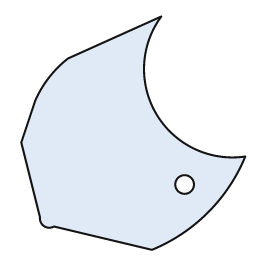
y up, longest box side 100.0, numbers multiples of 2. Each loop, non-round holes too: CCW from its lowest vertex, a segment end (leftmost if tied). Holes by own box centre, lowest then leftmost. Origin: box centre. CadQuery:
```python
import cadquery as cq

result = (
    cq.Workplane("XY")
    .moveTo(8.0, -50.0)
    .threePointArc((32.0, -34.0), (48.0, -10.0))
    .threePointArc((10.0, 8.0), (12.0, 50.0))
    .lineTo(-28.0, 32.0)
    .threePointArc((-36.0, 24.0), (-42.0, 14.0))
    .lineTo(-48.0, -4.0)
    .lineTo(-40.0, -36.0)
    .threePointArc((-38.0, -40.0), (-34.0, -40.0))
    .close()
    .moveTo(22.0, -22.0)
    .circle(4.0)
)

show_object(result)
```